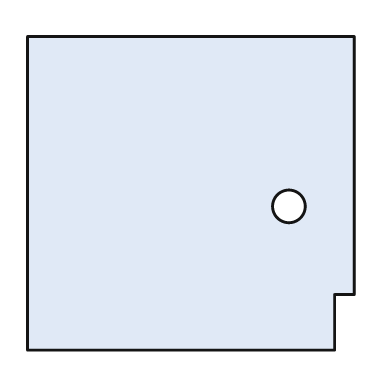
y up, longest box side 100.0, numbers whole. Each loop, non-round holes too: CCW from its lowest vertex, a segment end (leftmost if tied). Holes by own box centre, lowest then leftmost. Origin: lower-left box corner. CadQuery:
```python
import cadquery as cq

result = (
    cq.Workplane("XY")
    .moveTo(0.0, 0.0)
    .lineTo(94.0, 0.0)
    .lineTo(94.0, 17.0)
    .lineTo(100.0, 17.0)
    .lineTo(100.0, 96.0)
    .lineTo(0.0, 96.0)
    .close()
    .moveTo(80.0, 44.0)
    .circle(5.0)
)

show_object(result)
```